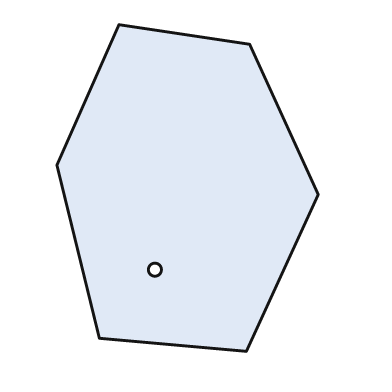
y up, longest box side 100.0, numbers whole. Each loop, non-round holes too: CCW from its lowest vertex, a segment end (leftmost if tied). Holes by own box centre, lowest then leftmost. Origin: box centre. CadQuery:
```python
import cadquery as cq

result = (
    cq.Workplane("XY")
    .moveTo(18.0, -50.0)
    .lineTo(40.0, -2.0)
    .lineTo(19.0, 44.0)
    .lineTo(-21.0, 50.0)
    .lineTo(-40.0, 7.0)
    .lineTo(-27.0, -46.0)
    .close()
    .moveTo(-10.0, -25.0)
    .circle(2.0)
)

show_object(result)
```